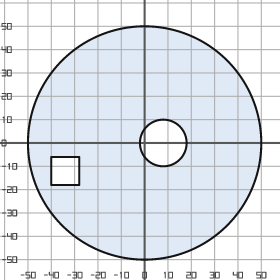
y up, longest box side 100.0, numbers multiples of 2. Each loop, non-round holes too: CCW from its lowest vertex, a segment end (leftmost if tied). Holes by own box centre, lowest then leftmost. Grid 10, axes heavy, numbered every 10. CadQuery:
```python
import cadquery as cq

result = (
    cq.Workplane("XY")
    .moveTo(0.0, 0.0)
    .circle(50.0)
    .moveTo(-40.0, -18.0)
    .lineTo(-28.0, -18.0)
    .lineTo(-28.0, -6.0)
    .lineTo(-40.0, -6.0)
    .close()
    .moveTo(8.0, 0.0)
    .circle(10.0)
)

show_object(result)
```